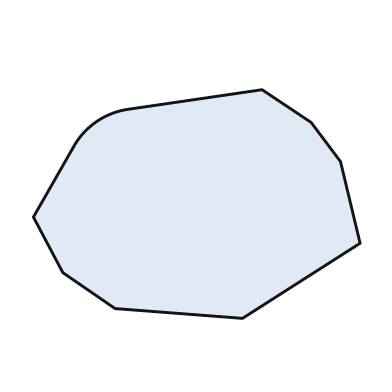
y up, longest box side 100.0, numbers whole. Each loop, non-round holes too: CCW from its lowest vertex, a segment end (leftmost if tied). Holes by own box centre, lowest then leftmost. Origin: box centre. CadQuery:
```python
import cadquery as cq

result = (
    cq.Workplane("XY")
    .moveTo(14.0, -35.0)
    .lineTo(50.0, -12.0)
    .lineTo(44.0, 13.0)
    .lineTo(35.0, 25.0)
    .lineTo(20.0, 35.0)
    .lineTo(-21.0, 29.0)
    .threePointArc((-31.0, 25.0), (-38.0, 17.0))
    .lineTo(-50.0, -4.0)
    .lineTo(-41.0, -21.0)
    .lineTo(-25.0, -32.0)
    .close()
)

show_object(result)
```